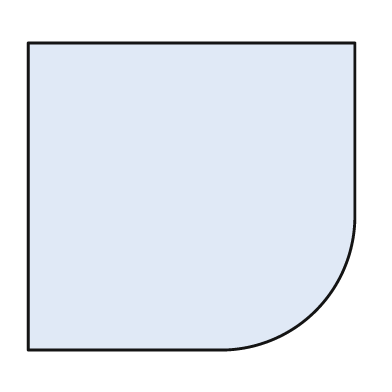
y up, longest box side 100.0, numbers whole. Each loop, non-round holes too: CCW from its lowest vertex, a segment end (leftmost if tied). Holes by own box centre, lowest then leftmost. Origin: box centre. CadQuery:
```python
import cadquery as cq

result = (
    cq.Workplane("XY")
    .moveTo(-50.0, -47.0)
    .lineTo(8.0, -47.0)
    .threePointArc((38.0, -35.0), (50.0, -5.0))
    .lineTo(50.0, 47.0)
    .lineTo(-50.0, 47.0)
    .close()
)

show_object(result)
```